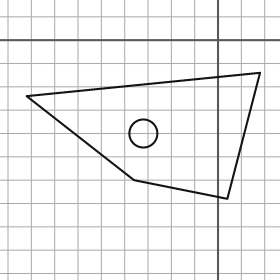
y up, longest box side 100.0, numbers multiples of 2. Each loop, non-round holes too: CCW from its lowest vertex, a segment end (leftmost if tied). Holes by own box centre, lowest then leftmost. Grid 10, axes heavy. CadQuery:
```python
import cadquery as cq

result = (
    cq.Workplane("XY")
    .moveTo(4.0, -68.0)
    .lineTo(18.0, -14.0)
    .lineTo(-82.0, -24.0)
    .lineTo(-36.0, -60.0)
    .close()
    .moveTo(-32.0, -40.0)
    .circle(6.0)
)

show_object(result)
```